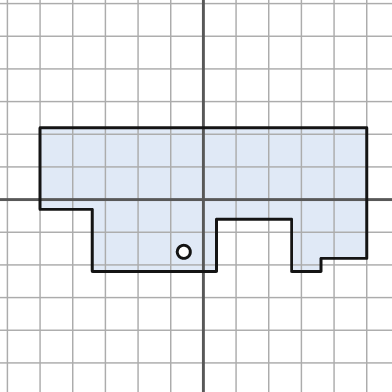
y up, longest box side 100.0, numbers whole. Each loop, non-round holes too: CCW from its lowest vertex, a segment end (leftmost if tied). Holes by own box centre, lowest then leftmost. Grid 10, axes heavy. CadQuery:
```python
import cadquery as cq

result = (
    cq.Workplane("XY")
    .moveTo(-34.0, -22.0)
    .lineTo(4.0, -22.0)
    .lineTo(4.0, -6.0)
    .lineTo(27.0, -6.0)
    .lineTo(27.0, -22.0)
    .lineTo(36.0, -22.0)
    .lineTo(36.0, -18.0)
    .lineTo(50.0, -18.0)
    .lineTo(50.0, 22.0)
    .lineTo(-50.0, 22.0)
    .lineTo(-50.0, -3.0)
    .lineTo(-34.0, -3.0)
    .close()
    .moveTo(-6.0, -16.0)
    .circle(2.0)
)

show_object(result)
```